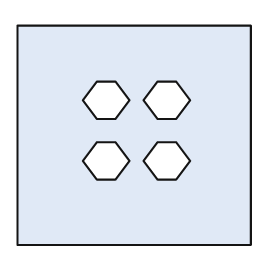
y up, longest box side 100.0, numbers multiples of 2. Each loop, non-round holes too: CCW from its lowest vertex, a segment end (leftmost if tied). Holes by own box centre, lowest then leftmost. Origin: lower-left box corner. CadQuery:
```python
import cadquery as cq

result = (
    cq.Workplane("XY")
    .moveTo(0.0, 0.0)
    .lineTo(100.0, 0.0)
    .lineTo(100.0, 94.0)
    .lineTo(0.0, 94.0)
    .close()
    .moveTo(34.0, 28.0)
    .lineTo(42.0, 28.0)
    .lineTo(48.0, 36.0)
    .lineTo(42.0, 44.0)
    .lineTo(34.0, 44.0)
    .lineTo(28.0, 36.0)
    .close()
    .moveTo(60.0, 28.0)
    .lineTo(68.0, 28.0)
    .lineTo(74.0, 36.0)
    .lineTo(68.0, 44.0)
    .lineTo(60.0, 44.0)
    .lineTo(54.0, 36.0)
    .close()
    .moveTo(34.0, 54.0)
    .lineTo(42.0, 54.0)
    .lineTo(48.0, 62.0)
    .lineTo(42.0, 70.0)
    .lineTo(34.0, 70.0)
    .lineTo(28.0, 62.0)
    .close()
    .moveTo(60.0, 54.0)
    .lineTo(68.0, 54.0)
    .lineTo(74.0, 62.0)
    .lineTo(68.0, 70.0)
    .lineTo(60.0, 70.0)
    .lineTo(54.0, 62.0)
    .close()
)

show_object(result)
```